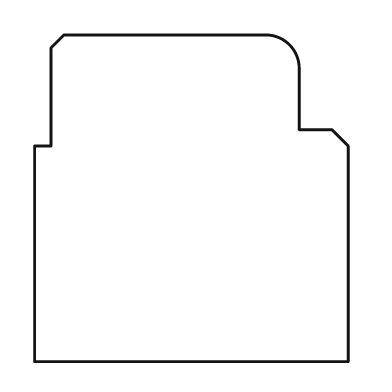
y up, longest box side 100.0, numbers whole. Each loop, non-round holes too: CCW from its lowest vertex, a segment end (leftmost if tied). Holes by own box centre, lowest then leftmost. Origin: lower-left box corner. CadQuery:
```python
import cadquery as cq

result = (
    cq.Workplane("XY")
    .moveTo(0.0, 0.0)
    .lineTo(96.0, 0.0)
    .lineTo(96.0, 66.0)
    .lineTo(91.0, 71.0)
    .lineTo(81.0, 71.0)
    .lineTo(81.0, 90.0)
    .threePointArc((78.0, 97.0), (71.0, 100.0))
    .lineTo(9.0, 100.0)
    .lineTo(5.0, 96.0)
    .lineTo(5.0, 66.0)
    .lineTo(0.0, 66.0)
    .close()
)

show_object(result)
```